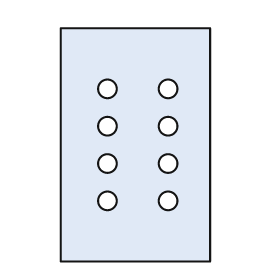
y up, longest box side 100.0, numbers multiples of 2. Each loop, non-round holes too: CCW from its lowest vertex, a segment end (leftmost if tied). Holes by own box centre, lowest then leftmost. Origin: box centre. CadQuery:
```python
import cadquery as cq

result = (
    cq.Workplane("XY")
    .moveTo(-32.0, -50.0)
    .lineTo(32.0, -50.0)
    .lineTo(32.0, 50.0)
    .lineTo(-32.0, 50.0)
    .close()
    .moveTo(-12.0, -24.0)
    .circle(4.0)
    .moveTo(14.0, -24.0)
    .circle(4.0)
    .moveTo(-12.0, -8.0)
    .circle(4.0)
    .moveTo(14.0, -8.0)
    .circle(4.0)
    .moveTo(-12.0, 8.0)
    .circle(4.0)
    .moveTo(14.0, 8.0)
    .circle(4.0)
    .moveTo(-12.0, 24.0)
    .circle(4.0)
    .moveTo(14.0, 24.0)
    .circle(4.0)
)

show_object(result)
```